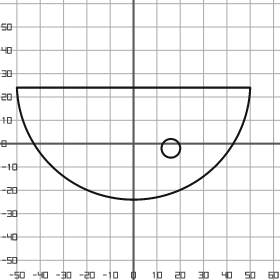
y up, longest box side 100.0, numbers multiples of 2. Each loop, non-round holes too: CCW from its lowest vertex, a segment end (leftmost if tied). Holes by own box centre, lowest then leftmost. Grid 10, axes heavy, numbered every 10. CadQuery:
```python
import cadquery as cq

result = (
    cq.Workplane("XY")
    .moveTo(-50.0, 24.0)
    .threePointArc((0.0, -24.0), (50.0, 24.0))
    .close()
    .moveTo(16.0, -2.0)
    .circle(4.0)
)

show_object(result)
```